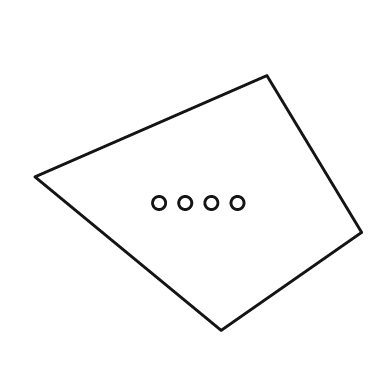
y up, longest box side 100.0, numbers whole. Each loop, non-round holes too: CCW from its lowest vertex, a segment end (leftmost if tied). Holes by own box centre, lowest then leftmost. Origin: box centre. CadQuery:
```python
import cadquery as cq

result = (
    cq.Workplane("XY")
    .moveTo(7.0, -39.0)
    .lineTo(50.0, -9.0)
    .lineTo(21.0, 39.0)
    .lineTo(-50.0, 8.0)
    .close()
    .moveTo(-12.0, 0.0)
    .circle(2.0)
    .moveTo(-4.0, 0.0)
    .circle(2.0)
    .moveTo(4.0, 0.0)
    .circle(2.0)
    .moveTo(12.0, 0.0)
    .circle(2.0)
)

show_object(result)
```